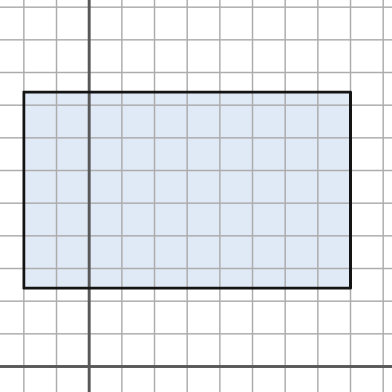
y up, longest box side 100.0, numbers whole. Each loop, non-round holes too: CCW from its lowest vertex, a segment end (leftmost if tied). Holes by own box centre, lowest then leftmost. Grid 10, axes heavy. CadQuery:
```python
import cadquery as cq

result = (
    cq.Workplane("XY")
    .moveTo(-20.0, 24.0)
    .lineTo(80.0, 24.0)
    .lineTo(80.0, 84.0)
    .lineTo(-20.0, 84.0)
    .close()
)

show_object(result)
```